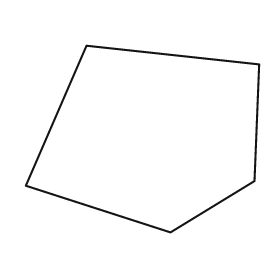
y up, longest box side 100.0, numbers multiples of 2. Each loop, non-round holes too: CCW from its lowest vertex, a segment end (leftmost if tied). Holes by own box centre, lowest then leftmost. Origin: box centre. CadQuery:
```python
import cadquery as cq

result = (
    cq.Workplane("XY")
    .moveTo(12.0, -40.0)
    .lineTo(48.0, -18.0)
    .lineTo(50.0, 32.0)
    .lineTo(-24.0, 40.0)
    .lineTo(-50.0, -20.0)
    .close()
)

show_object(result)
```